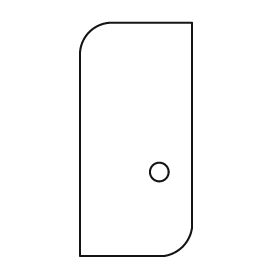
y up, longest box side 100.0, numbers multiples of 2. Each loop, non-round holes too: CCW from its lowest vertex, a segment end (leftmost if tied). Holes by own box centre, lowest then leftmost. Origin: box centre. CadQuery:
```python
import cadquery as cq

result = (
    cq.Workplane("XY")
    .moveTo(-24.0, -50.0)
    .lineTo(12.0, -50.0)
    .threePointArc((20.0, -46.0), (24.0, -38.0))
    .lineTo(24.0, 50.0)
    .lineTo(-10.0, 50.0)
    .threePointArc((-20.0, 46.0), (-24.0, 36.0))
    .close()
    .moveTo(10.0, -14.0)
    .circle(4.0)
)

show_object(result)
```